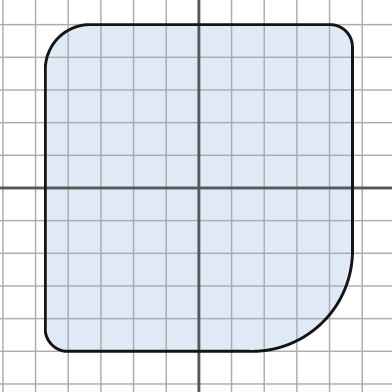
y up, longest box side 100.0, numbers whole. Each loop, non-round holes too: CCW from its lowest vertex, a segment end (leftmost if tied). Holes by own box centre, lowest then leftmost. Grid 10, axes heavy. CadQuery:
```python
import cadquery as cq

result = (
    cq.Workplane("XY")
    .moveTo(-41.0, -50.0)
    .lineTo(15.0, -50.0)
    .threePointArc((38.0, -41.0), (47.0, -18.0))
    .lineTo(47.0, 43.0)
    .threePointArc((45.0, 48.0), (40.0, 50.0))
    .lineTo(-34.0, 50.0)
    .threePointArc((-43.0, 46.0), (-47.0, 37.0))
    .lineTo(-47.0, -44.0)
    .threePointArc((-45.0, -48.0), (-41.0, -50.0))
    .close()
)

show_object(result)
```